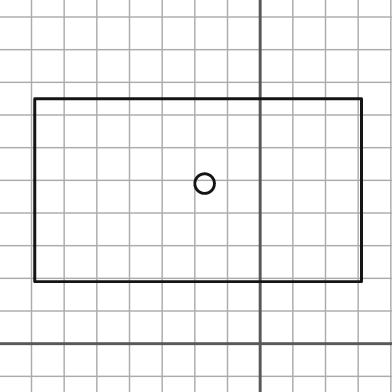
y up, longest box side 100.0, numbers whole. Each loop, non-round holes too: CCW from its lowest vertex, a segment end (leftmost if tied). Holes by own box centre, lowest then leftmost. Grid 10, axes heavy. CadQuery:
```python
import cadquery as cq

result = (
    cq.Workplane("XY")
    .moveTo(-69.0, 19.0)
    .lineTo(31.0, 19.0)
    .lineTo(31.0, 75.0)
    .lineTo(-69.0, 75.0)
    .close()
    .moveTo(-17.0, 49.0)
    .circle(3.0)
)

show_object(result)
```